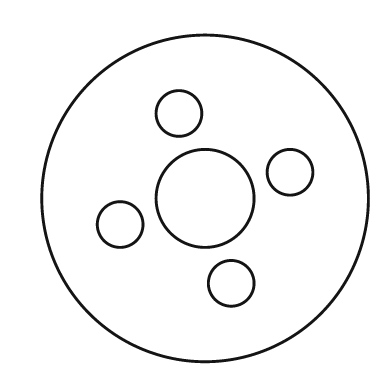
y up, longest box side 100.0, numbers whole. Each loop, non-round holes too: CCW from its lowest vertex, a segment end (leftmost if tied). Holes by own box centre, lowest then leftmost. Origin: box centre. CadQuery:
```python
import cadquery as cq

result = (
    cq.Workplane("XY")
    .moveTo(0.0, 0.0)
    .circle(50.0)
    .moveTo(8.0, -26.0)
    .circle(7.0)
    .moveTo(-26.0, -8.0)
    .circle(7.0)
    .moveTo(0.0, 0.0)
    .circle(15.0)
    .moveTo(26.0, 8.0)
    .circle(7.0)
    .moveTo(-8.0, 26.0)
    .circle(7.0)
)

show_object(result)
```